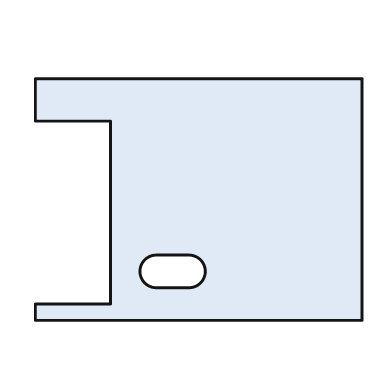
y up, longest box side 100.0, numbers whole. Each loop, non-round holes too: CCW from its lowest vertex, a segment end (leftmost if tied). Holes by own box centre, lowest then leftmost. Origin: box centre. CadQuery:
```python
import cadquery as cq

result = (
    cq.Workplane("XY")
    .moveTo(-50.0, -37.0)
    .lineTo(50.0, -37.0)
    .lineTo(50.0, 37.0)
    .lineTo(-50.0, 37.0)
    .lineTo(-50.0, 24.0)
    .lineTo(-27.0, 24.0)
    .lineTo(-27.0, -32.0)
    .lineTo(-50.0, -32.0)
    .close()
    .moveTo(-13.0, -27.0)
    .lineTo(-3.0, -27.0)
    .threePointArc((2.0, -22.0), (-3.0, -17.0))
    .lineTo(-13.0, -17.0)
    .threePointArc((-18.0, -22.0), (-13.0, -27.0))
    .close()
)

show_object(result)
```